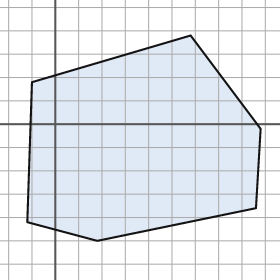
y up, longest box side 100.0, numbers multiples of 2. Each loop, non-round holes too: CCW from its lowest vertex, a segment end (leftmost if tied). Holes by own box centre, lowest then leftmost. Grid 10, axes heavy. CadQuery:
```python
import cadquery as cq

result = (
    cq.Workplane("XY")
    .moveTo(18.0, -50.0)
    .lineTo(86.0, -36.0)
    .lineTo(88.0, -2.0)
    .lineTo(58.0, 38.0)
    .lineTo(-10.0, 18.0)
    .lineTo(-12.0, -42.0)
    .close()
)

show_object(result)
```